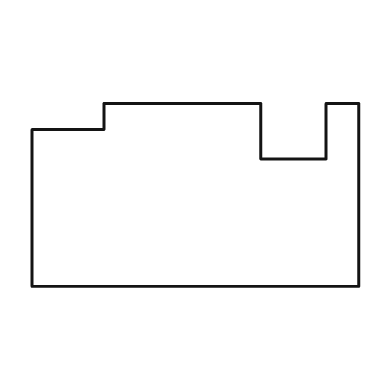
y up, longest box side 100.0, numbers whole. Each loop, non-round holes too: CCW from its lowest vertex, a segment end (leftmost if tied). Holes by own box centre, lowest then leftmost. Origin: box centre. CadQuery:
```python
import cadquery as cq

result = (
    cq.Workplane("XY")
    .moveTo(-50.0, -28.0)
    .lineTo(50.0, -28.0)
    .lineTo(50.0, 28.0)
    .lineTo(40.0, 28.0)
    .lineTo(40.0, 11.0)
    .lineTo(20.0, 11.0)
    .lineTo(20.0, 28.0)
    .lineTo(-28.0, 28.0)
    .lineTo(-28.0, 20.0)
    .lineTo(-50.0, 20.0)
    .close()
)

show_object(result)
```